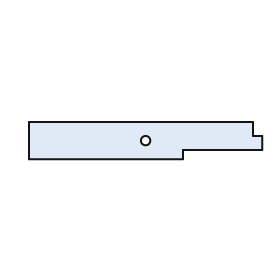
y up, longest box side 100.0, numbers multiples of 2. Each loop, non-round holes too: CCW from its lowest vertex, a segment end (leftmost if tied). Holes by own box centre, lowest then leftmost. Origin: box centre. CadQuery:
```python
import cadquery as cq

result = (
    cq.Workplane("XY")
    .moveTo(-50.0, -8.0)
    .lineTo(16.0, -8.0)
    .lineTo(16.0, -4.0)
    .lineTo(50.0, -4.0)
    .lineTo(50.0, 2.0)
    .lineTo(46.0, 2.0)
    .lineTo(46.0, 8.0)
    .lineTo(-50.0, 8.0)
    .close()
    .moveTo(0.0, 0.0)
    .circle(2.0)
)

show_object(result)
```